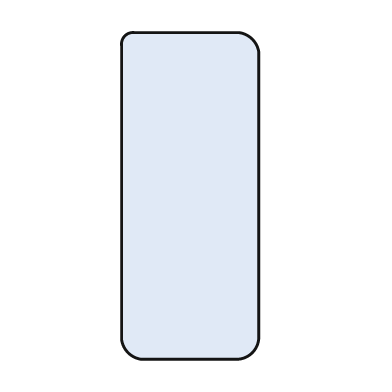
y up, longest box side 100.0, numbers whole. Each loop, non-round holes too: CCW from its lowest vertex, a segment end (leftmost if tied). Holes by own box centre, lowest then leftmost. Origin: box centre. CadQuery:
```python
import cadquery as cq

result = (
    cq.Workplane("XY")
    .moveTo(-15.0, -50.0)
    .lineTo(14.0, -50.0)
    .threePointArc((19.0, -48.0), (21.0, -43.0))
    .lineTo(21.0, 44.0)
    .threePointArc((19.0, 48.0), (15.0, 50.0))
    .lineTo(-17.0, 50.0)
    .threePointArc((-20.0, 49.0), (-21.0, 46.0))
    .lineTo(-21.0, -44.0)
    .threePointArc((-19.0, -48.0), (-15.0, -50.0))
    .close()
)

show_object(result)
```